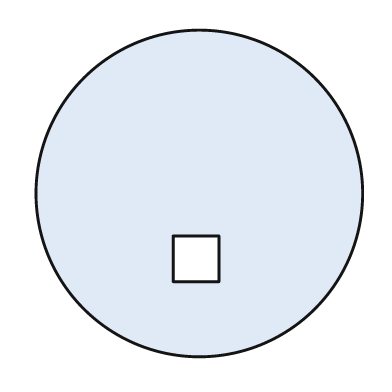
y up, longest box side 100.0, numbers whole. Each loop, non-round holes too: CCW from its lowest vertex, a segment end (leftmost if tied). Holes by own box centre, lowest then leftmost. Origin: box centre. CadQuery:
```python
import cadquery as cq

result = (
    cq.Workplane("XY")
    .moveTo(0.0, 0.0)
    .circle(50.0)
    .moveTo(-8.0, -27.0)
    .lineTo(6.0, -27.0)
    .lineTo(6.0, -13.0)
    .lineTo(-8.0, -13.0)
    .close()
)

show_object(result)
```